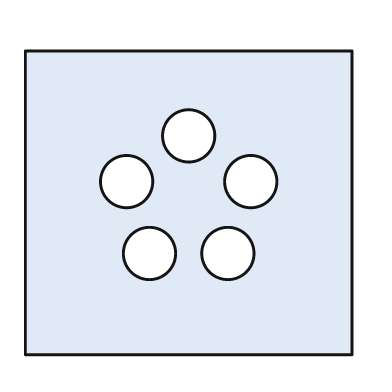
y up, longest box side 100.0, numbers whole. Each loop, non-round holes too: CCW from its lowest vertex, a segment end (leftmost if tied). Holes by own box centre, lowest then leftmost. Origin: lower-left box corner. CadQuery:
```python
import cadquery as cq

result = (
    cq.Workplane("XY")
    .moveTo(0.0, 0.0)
    .lineTo(100.0, 0.0)
    .lineTo(100.0, 93.0)
    .lineTo(0.0, 93.0)
    .close()
    .moveTo(38.0, 31.0)
    .circle(8.0)
    .moveTo(62.0, 31.0)
    .circle(8.0)
    .moveTo(31.0, 53.0)
    .circle(8.0)
    .moveTo(69.0, 53.0)
    .circle(8.0)
    .moveTo(50.0, 67.0)
    .circle(8.0)
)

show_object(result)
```